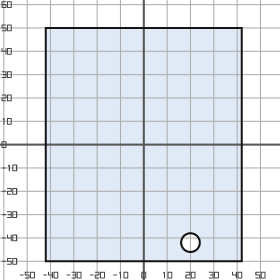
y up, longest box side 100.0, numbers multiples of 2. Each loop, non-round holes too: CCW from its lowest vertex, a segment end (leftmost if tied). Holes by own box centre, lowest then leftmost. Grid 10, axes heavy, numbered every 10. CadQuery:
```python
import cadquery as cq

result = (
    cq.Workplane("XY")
    .moveTo(-42.0, -50.0)
    .lineTo(42.0, -50.0)
    .lineTo(42.0, 50.0)
    .lineTo(-42.0, 50.0)
    .close()
    .moveTo(20.0, -42.0)
    .circle(4.0)
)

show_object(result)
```